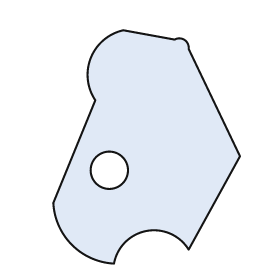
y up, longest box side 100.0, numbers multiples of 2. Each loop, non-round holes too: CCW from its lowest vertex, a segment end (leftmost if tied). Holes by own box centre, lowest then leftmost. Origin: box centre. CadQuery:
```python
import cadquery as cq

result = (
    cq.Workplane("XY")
    .moveTo(-14.0, -50.0)
    .threePointArc((0.0, -36.0), (18.0, -44.0))
    .lineTo(40.0, -4.0)
    .lineTo(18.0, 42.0)
    .threePointArc((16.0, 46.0), (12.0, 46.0))
    .lineTo(-10.0, 50.0)
    .threePointArc((-24.0, 38.0), (-22.0, 20.0))
    .lineTo(-40.0, -24.0)
    .threePointArc((-32.0, -42.0), (-14.0, -50.0))
    .close()
    .moveTo(-16.0, -10.0)
    .circle(8.0)
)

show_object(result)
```